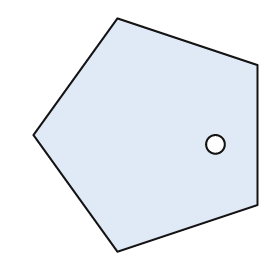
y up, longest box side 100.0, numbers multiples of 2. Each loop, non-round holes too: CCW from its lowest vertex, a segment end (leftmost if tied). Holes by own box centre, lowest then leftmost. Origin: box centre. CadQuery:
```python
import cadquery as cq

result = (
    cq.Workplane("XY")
    .moveTo(-12.0, -50.0)
    .lineTo(48.0, -30.0)
    .lineTo(48.0, 30.0)
    .lineTo(-12.0, 50.0)
    .lineTo(-48.0, 0.0)
    .close()
    .moveTo(30.0, -4.0)
    .circle(4.0)
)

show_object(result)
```